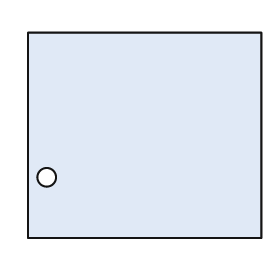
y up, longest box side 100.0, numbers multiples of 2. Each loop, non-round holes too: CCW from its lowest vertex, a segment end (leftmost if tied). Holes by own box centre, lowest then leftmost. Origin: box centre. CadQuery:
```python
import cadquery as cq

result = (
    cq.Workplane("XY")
    .moveTo(-50.0, -44.0)
    .lineTo(50.0, -44.0)
    .lineTo(50.0, 44.0)
    .lineTo(-50.0, 44.0)
    .close()
    .moveTo(-42.0, -18.0)
    .circle(4.0)
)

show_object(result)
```